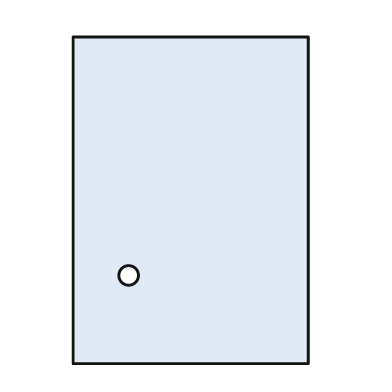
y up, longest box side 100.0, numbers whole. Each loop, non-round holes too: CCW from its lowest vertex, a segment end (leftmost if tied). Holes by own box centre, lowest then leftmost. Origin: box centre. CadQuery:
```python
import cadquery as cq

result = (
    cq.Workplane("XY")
    .moveTo(-36.0, -50.0)
    .lineTo(36.0, -50.0)
    .lineTo(36.0, 50.0)
    .lineTo(-36.0, 50.0)
    .close()
    .moveTo(-19.0, -23.0)
    .circle(3.0)
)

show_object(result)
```